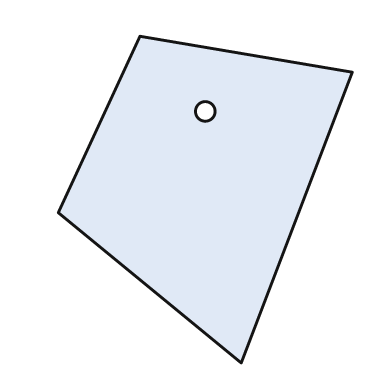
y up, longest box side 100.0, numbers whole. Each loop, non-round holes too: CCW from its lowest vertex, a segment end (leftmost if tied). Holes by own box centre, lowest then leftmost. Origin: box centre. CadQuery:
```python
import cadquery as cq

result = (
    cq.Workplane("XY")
    .moveTo(11.0, -50.0)
    .lineTo(45.0, 39.0)
    .lineTo(-20.0, 50.0)
    .lineTo(-45.0, -4.0)
    .close()
    .moveTo(0.0, 27.0)
    .circle(3.0)
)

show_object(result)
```